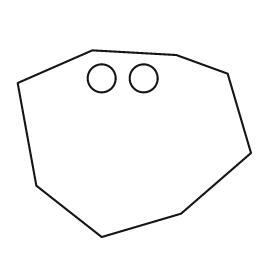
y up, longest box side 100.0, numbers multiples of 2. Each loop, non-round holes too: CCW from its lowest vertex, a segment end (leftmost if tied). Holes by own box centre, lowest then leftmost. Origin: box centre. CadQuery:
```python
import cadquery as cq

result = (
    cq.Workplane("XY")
    .moveTo(-14.0, -40.0)
    .lineTo(20.0, -30.0)
    .lineTo(50.0, -4.0)
    .lineTo(40.0, 30.0)
    .lineTo(18.0, 38.0)
    .lineTo(-18.0, 40.0)
    .lineTo(-50.0, 26.0)
    .lineTo(-42.0, -18.0)
    .close()
    .moveTo(-14.0, 28.0)
    .circle(6.0)
    .moveTo(4.0, 28.0)
    .circle(6.0)
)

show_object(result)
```